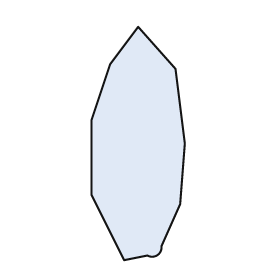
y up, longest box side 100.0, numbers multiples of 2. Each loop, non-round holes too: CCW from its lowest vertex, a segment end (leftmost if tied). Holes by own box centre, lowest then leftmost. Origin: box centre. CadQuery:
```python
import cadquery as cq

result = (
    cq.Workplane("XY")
    .moveTo(-6.0, -50.0)
    .lineTo(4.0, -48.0)
    .threePointArc((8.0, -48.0), (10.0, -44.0))
    .lineTo(18.0, -26.0)
    .lineTo(20.0, 0.0)
    .lineTo(16.0, 32.0)
    .lineTo(0.0, 50.0)
    .lineTo(-12.0, 34.0)
    .lineTo(-20.0, 10.0)
    .lineTo(-20.0, -22.0)
    .close()
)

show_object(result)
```